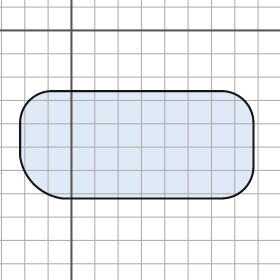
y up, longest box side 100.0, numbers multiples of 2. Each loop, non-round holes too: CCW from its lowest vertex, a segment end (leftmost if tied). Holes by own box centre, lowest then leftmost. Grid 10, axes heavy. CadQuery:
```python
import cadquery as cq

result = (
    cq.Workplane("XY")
    .moveTo(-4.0, -72.0)
    .lineTo(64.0, -72.0)
    .threePointArc((74.0, -68.0), (78.0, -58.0))
    .lineTo(78.0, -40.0)
    .threePointArc((74.0, -30.0), (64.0, -26.0))
    .lineTo(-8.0, -26.0)
    .threePointArc((-18.0, -30.0), (-22.0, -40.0))
    .lineTo(-22.0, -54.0)
    .threePointArc((-16.0, -66.0), (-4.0, -72.0))
    .close()
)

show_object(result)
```